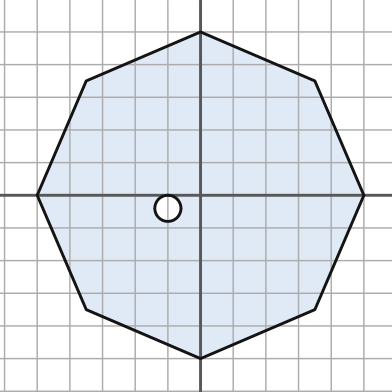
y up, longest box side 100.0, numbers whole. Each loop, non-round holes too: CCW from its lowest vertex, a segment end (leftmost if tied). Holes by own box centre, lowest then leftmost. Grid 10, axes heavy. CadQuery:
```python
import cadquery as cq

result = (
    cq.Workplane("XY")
    .moveTo(0.0, -50.0)
    .lineTo(35.0, -35.0)
    .lineTo(50.0, 0.0)
    .lineTo(35.0, 35.0)
    .lineTo(0.0, 50.0)
    .lineTo(-35.0, 35.0)
    .lineTo(-50.0, 0.0)
    .lineTo(-35.0, -35.0)
    .close()
    .moveTo(-10.0, -4.0)
    .circle(4.0)
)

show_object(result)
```